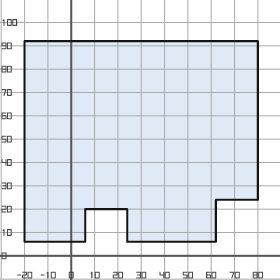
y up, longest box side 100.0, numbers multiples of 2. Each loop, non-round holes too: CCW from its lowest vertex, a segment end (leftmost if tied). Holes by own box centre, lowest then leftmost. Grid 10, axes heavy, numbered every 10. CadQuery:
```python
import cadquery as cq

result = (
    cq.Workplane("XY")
    .moveTo(-20.0, 6.0)
    .lineTo(6.0, 6.0)
    .lineTo(6.0, 20.0)
    .lineTo(24.0, 20.0)
    .lineTo(24.0, 6.0)
    .lineTo(62.0, 6.0)
    .lineTo(62.0, 24.0)
    .lineTo(80.0, 24.0)
    .lineTo(80.0, 92.0)
    .lineTo(-20.0, 92.0)
    .close()
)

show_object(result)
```